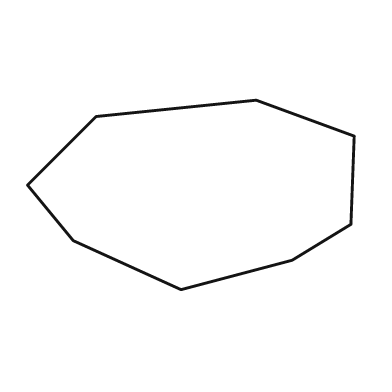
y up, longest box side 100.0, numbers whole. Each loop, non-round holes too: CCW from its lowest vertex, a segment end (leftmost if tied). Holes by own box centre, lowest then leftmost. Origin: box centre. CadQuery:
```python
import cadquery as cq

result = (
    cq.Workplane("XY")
    .moveTo(-3.0, -29.0)
    .lineTo(31.0, -20.0)
    .lineTo(49.0, -9.0)
    .lineTo(50.0, 18.0)
    .lineTo(20.0, 29.0)
    .lineTo(-29.0, 24.0)
    .lineTo(-50.0, 3.0)
    .lineTo(-36.0, -14.0)
    .close()
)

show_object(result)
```